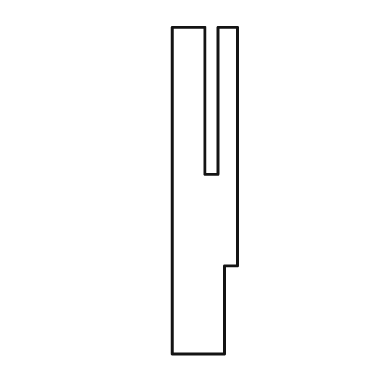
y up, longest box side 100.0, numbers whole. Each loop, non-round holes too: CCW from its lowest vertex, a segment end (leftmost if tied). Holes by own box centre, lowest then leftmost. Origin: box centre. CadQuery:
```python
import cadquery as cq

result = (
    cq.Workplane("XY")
    .moveTo(-10.0, -50.0)
    .lineTo(6.0, -50.0)
    .lineTo(6.0, -23.0)
    .lineTo(10.0, -23.0)
    .lineTo(10.0, 50.0)
    .lineTo(4.0, 50.0)
    .lineTo(4.0, 5.0)
    .lineTo(0.0, 5.0)
    .lineTo(0.0, 50.0)
    .lineTo(-10.0, 50.0)
    .close()
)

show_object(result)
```